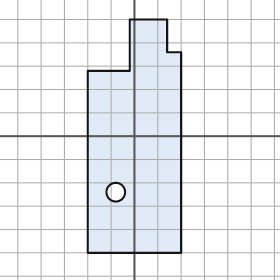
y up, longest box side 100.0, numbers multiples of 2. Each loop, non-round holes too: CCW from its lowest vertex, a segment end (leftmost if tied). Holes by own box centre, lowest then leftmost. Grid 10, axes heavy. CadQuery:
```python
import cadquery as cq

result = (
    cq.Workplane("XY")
    .moveTo(-20.0, -50.0)
    .lineTo(20.0, -50.0)
    .lineTo(20.0, 36.0)
    .lineTo(14.0, 36.0)
    .lineTo(14.0, 50.0)
    .lineTo(-2.0, 50.0)
    .lineTo(-2.0, 28.0)
    .lineTo(-20.0, 28.0)
    .close()
    .moveTo(-8.0, -24.0)
    .circle(4.0)
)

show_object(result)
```